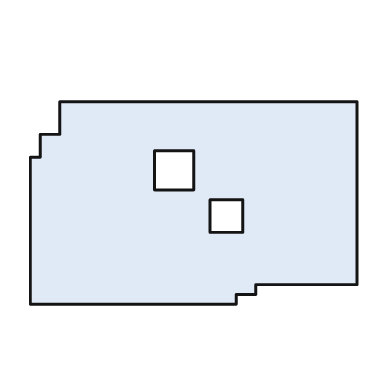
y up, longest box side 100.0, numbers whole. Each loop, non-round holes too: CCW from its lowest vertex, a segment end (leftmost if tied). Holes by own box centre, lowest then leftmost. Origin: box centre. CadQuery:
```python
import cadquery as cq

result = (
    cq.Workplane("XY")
    .moveTo(-50.0, -31.0)
    .lineTo(13.0, -31.0)
    .lineTo(13.0, -28.0)
    .lineTo(19.0, -28.0)
    .lineTo(19.0, -25.0)
    .lineTo(50.0, -25.0)
    .lineTo(50.0, 31.0)
    .lineTo(-41.0, 31.0)
    .lineTo(-41.0, 21.0)
    .lineTo(-47.0, 21.0)
    .lineTo(-47.0, 14.0)
    .lineTo(-50.0, 14.0)
    .close()
    .moveTo(5.0, -9.0)
    .lineTo(15.0, -9.0)
    .lineTo(15.0, 1.0)
    .lineTo(5.0, 1.0)
    .close()
    .moveTo(-12.0, 4.0)
    .lineTo(0.0, 4.0)
    .lineTo(0.0, 16.0)
    .lineTo(-12.0, 16.0)
    .close()
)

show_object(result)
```